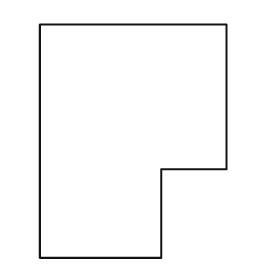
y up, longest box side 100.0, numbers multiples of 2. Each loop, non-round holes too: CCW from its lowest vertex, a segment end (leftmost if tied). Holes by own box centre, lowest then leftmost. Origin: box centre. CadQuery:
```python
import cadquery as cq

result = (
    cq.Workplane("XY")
    .moveTo(-40.0, -50.0)
    .lineTo(12.0, -50.0)
    .lineTo(12.0, -12.0)
    .lineTo(40.0, -12.0)
    .lineTo(40.0, 50.0)
    .lineTo(-40.0, 50.0)
    .close()
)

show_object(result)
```